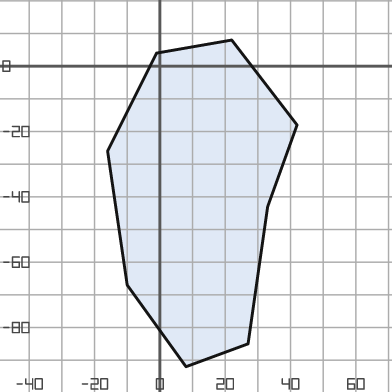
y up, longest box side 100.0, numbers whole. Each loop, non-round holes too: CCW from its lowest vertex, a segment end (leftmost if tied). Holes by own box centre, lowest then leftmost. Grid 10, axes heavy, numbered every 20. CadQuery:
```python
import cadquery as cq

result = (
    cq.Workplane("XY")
    .moveTo(8.0, -92.0)
    .lineTo(27.0, -85.0)
    .lineTo(33.0, -43.0)
    .lineTo(42.0, -18.0)
    .lineTo(22.0, 8.0)
    .lineTo(-1.0, 4.0)
    .lineTo(-16.0, -26.0)
    .lineTo(-10.0, -67.0)
    .close()
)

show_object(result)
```